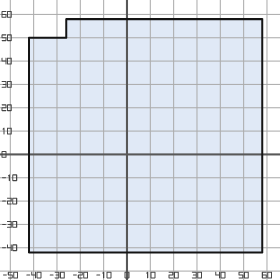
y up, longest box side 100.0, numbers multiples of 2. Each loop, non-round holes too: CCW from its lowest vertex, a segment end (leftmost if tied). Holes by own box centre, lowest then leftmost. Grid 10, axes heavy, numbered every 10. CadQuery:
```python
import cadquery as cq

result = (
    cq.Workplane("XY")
    .moveTo(-42.0, -42.0)
    .lineTo(58.0, -42.0)
    .lineTo(58.0, 58.0)
    .lineTo(-26.0, 58.0)
    .lineTo(-26.0, 50.0)
    .lineTo(-42.0, 50.0)
    .close()
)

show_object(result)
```